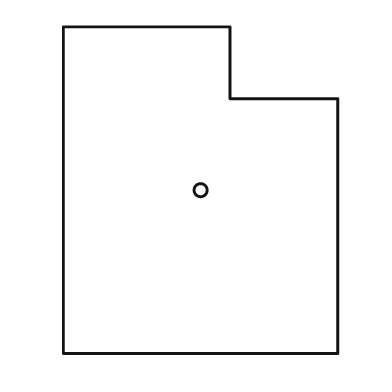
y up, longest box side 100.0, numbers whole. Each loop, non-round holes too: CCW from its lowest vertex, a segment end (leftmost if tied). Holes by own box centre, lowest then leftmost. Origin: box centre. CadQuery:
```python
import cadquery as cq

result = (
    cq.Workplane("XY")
    .moveTo(-42.0, -50.0)
    .lineTo(42.0, -50.0)
    .lineTo(42.0, 28.0)
    .lineTo(9.0, 28.0)
    .lineTo(9.0, 50.0)
    .lineTo(-42.0, 50.0)
    .close()
    .moveTo(0.0, 0.0)
    .circle(2.0)
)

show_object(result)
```